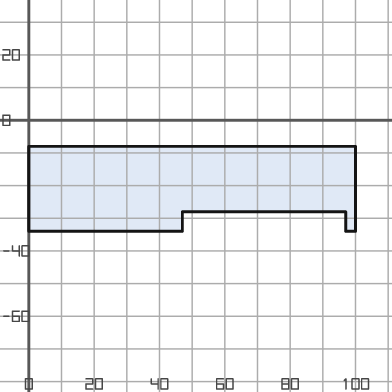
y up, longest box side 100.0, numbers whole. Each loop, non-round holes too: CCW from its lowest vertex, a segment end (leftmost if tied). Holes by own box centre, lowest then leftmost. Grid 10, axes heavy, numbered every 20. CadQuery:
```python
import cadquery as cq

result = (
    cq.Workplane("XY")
    .moveTo(0.0, -34.0)
    .lineTo(47.0, -34.0)
    .lineTo(47.0, -28.0)
    .lineTo(97.0, -28.0)
    .lineTo(97.0, -34.0)
    .lineTo(100.0, -34.0)
    .lineTo(100.0, -8.0)
    .lineTo(0.0, -8.0)
    .close()
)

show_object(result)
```